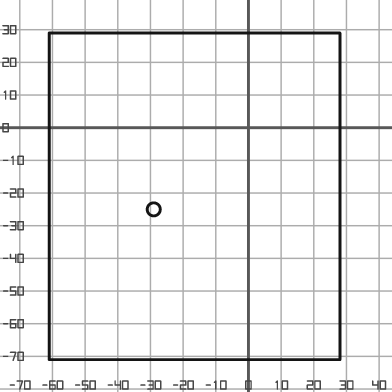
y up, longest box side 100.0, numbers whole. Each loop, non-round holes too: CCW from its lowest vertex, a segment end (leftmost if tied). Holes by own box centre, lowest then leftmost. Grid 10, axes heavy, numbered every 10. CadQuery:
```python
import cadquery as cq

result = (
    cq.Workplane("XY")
    .moveTo(-61.0, -71.0)
    .lineTo(28.0, -71.0)
    .lineTo(28.0, 29.0)
    .lineTo(-61.0, 29.0)
    .close()
    .moveTo(-29.0, -25.0)
    .circle(2.0)
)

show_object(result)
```